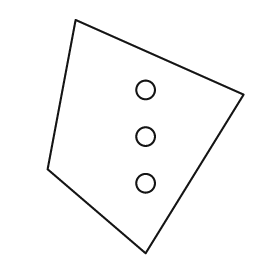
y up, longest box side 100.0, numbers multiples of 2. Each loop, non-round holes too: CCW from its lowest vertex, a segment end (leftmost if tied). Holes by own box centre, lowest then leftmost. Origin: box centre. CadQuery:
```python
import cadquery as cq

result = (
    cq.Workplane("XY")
    .moveTo(0.0, -50.0)
    .lineTo(42.0, 18.0)
    .lineTo(-30.0, 50.0)
    .lineTo(-42.0, -14.0)
    .close()
    .moveTo(0.0, -20.0)
    .circle(4.0)
    .moveTo(0.0, 0.0)
    .circle(4.0)
    .moveTo(0.0, 20.0)
    .circle(4.0)
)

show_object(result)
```